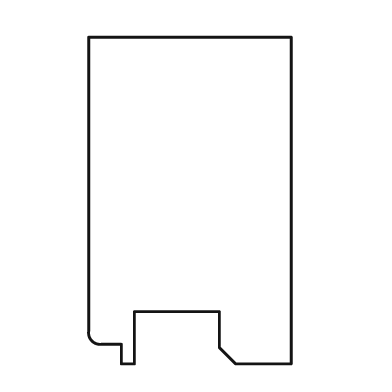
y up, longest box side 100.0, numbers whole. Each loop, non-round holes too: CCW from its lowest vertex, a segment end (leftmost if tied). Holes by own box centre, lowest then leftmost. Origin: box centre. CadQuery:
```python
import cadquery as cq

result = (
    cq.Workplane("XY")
    .moveTo(-21.0, -50.0)
    .lineTo(-17.0, -50.0)
    .lineTo(-17.0, -34.0)
    .lineTo(9.0, -34.0)
    .lineTo(9.0, -45.0)
    .lineTo(14.0, -50.0)
    .lineTo(31.0, -50.0)
    .lineTo(31.0, 50.0)
    .lineTo(-31.0, 50.0)
    .lineTo(-31.0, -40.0)
    .threePointArc((-30.0, -43.0), (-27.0, -44.0))
    .lineTo(-21.0, -44.0)
    .close()
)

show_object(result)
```